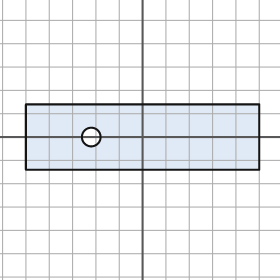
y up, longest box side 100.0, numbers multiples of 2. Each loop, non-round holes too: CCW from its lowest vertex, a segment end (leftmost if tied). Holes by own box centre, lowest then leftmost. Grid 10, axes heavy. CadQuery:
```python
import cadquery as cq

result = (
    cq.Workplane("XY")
    .moveTo(-50.0, -14.0)
    .lineTo(50.0, -14.0)
    .lineTo(50.0, 14.0)
    .lineTo(-50.0, 14.0)
    .close()
    .moveTo(-22.0, 0.0)
    .circle(4.0)
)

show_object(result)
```